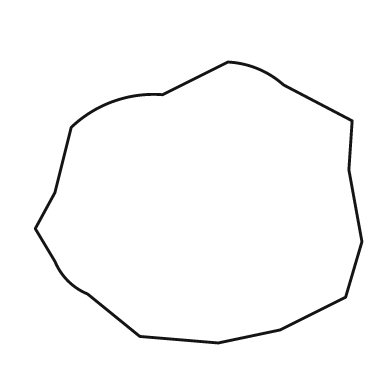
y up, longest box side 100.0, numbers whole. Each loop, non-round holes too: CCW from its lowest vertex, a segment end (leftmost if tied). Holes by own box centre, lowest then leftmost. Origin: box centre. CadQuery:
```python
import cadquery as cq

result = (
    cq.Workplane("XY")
    .moveTo(6.0, -43.0)
    .lineTo(25.0, -39.0)
    .lineTo(45.0, -29.0)
    .lineTo(50.0, -12.0)
    .lineTo(46.0, 10.0)
    .lineTo(47.0, 25.0)
    .lineTo(26.0, 36.0)
    .threePointArc((18.0, 41.0), (9.0, 43.0))
    .lineTo(-11.0, 33.0)
    .threePointArc((-26.0, 31.0), (-39.0, 23.0))
    .lineTo(-44.0, 3.0)
    .lineTo(-50.0, -8.0)
    .lineTo(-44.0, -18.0)
    .threePointArc((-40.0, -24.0), (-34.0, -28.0))
    .lineTo(-18.0, -41.0)
    .close()
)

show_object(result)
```